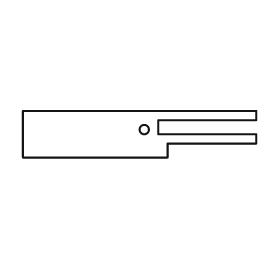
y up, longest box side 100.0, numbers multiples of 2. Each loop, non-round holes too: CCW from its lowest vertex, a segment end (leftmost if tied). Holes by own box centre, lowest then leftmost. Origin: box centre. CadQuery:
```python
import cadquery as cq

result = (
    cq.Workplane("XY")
    .moveTo(-50.0, -10.0)
    .lineTo(12.0, -10.0)
    .lineTo(12.0, -4.0)
    .lineTo(50.0, -4.0)
    .lineTo(50.0, 0.0)
    .lineTo(8.0, 0.0)
    .lineTo(8.0, 6.0)
    .lineTo(50.0, 6.0)
    .lineTo(50.0, 10.0)
    .lineTo(-50.0, 10.0)
    .close()
    .moveTo(2.0, 2.0)
    .circle(2.0)
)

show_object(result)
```